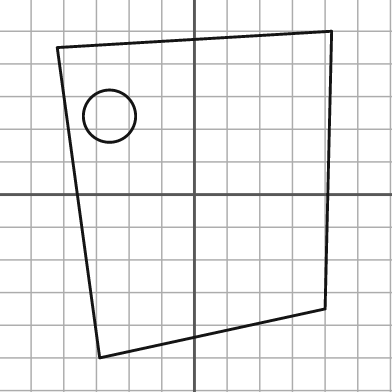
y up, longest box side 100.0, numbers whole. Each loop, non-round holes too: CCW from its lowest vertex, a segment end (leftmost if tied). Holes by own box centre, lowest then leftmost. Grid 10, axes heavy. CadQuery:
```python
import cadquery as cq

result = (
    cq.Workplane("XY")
    .moveTo(-29.0, -50.0)
    .lineTo(40.0, -35.0)
    .lineTo(42.0, 50.0)
    .lineTo(-42.0, 45.0)
    .close()
    .moveTo(-26.0, 24.0)
    .circle(8.0)
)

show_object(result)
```